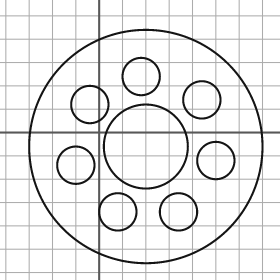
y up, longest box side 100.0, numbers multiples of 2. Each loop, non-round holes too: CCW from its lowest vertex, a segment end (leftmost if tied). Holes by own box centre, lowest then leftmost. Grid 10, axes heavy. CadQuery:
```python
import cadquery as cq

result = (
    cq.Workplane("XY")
    .moveTo(20.0, -6.0)
    .circle(50.0)
    .moveTo(8.0, -34.0)
    .circle(8.0)
    .moveTo(34.0, -34.0)
    .circle(8.0)
    .moveTo(-10.0, -14.0)
    .circle(8.0)
    .moveTo(50.0, -12.0)
    .circle(8.0)
    .moveTo(20.0, -6.0)
    .circle(18.0)
    .moveTo(-4.0, 12.0)
    .circle(8.0)
    .moveTo(44.0, 14.0)
    .circle(8.0)
    .moveTo(18.0, 24.0)
    .circle(8.0)
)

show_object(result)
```